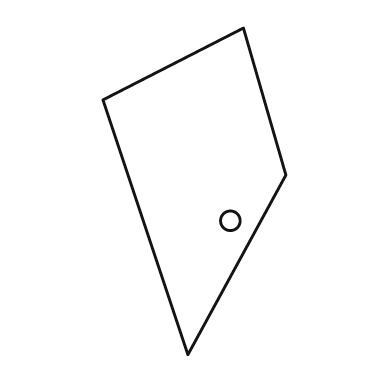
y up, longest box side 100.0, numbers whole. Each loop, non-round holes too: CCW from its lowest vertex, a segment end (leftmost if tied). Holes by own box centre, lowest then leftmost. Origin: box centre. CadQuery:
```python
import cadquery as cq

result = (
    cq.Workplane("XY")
    .moveTo(-2.0, -50.0)
    .lineTo(28.0, 5.0)
    .lineTo(15.0, 50.0)
    .lineTo(-28.0, 28.0)
    .close()
    .moveTo(11.0, -9.0)
    .circle(3.0)
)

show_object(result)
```